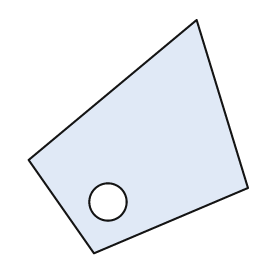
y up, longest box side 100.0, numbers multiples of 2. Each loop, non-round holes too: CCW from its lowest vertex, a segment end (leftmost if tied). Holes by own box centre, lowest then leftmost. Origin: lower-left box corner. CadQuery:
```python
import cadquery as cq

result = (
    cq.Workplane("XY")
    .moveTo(28.0, 0.0)
    .lineTo(94.0, 28.0)
    .lineTo(72.0, 100.0)
    .lineTo(0.0, 40.0)
    .close()
    .moveTo(34.0, 22.0)
    .circle(8.0)
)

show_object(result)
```